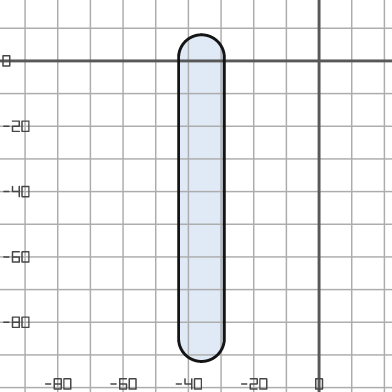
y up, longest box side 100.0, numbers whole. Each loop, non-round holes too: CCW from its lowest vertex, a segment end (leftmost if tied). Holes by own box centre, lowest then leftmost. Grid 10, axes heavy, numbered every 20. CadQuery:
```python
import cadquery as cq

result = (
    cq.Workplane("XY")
    .moveTo(-43.0, -85.0)
    .threePointArc((-36.0, -92.0), (-29.0, -85.0))
    .lineTo(-29.0, 1.0)
    .threePointArc((-36.0, 8.0), (-43.0, 1.0))
    .close()
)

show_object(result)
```